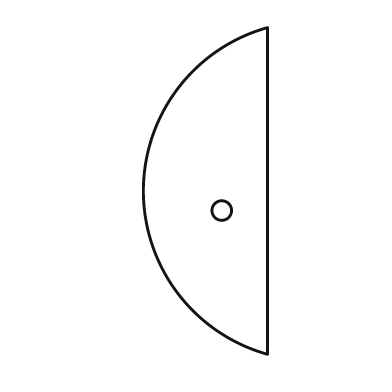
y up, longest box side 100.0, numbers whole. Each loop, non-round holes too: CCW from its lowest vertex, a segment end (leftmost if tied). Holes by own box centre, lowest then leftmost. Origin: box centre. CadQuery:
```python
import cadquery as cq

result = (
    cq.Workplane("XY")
    .moveTo(19.0, -50.0)
    .lineTo(19.0, 50.0)
    .threePointArc((-19.0, 0.0), (19.0, -50.0))
    .close()
    .moveTo(5.0, -6.0)
    .circle(3.0)
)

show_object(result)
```